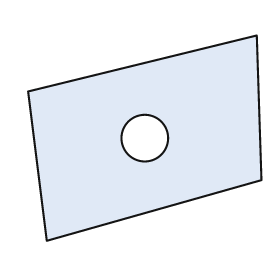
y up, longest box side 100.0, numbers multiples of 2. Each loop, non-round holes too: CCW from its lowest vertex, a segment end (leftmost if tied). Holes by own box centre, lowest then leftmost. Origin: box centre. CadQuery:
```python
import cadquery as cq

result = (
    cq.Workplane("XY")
    .moveTo(-42.0, -44.0)
    .lineTo(50.0, -18.0)
    .lineTo(48.0, 44.0)
    .lineTo(-50.0, 20.0)
    .close()
    .moveTo(0.0, 0.0)
    .circle(10.0)
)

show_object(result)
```